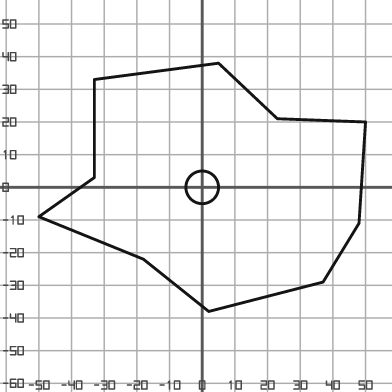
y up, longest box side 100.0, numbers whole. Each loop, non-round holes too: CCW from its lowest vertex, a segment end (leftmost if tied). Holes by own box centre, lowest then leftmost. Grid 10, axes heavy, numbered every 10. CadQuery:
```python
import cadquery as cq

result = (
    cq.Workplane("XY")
    .moveTo(2.0, -38.0)
    .lineTo(37.0, -29.0)
    .lineTo(48.0, -11.0)
    .lineTo(50.0, 20.0)
    .lineTo(23.0, 21.0)
    .lineTo(5.0, 38.0)
    .lineTo(-33.0, 33.0)
    .lineTo(-33.0, 3.0)
    .lineTo(-50.0, -9.0)
    .lineTo(-18.0, -22.0)
    .close()
    .moveTo(0.0, 0.0)
    .circle(5.0)
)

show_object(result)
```